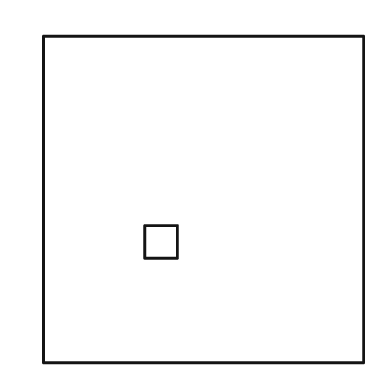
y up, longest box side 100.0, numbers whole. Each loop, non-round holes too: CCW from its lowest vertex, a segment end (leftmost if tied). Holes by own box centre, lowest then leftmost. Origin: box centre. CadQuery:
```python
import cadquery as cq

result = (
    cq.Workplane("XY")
    .moveTo(-49.0, -50.0)
    .lineTo(49.0, -50.0)
    .lineTo(49.0, 50.0)
    .lineTo(-49.0, 50.0)
    .close()
    .moveTo(-18.0, -18.0)
    .lineTo(-8.0, -18.0)
    .lineTo(-8.0, -8.0)
    .lineTo(-18.0, -8.0)
    .close()
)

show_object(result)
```